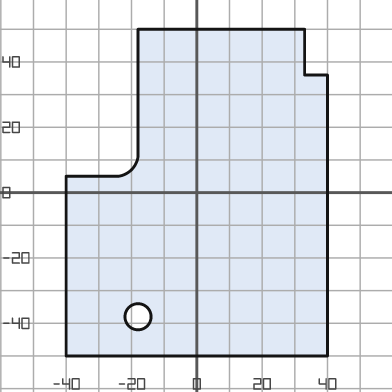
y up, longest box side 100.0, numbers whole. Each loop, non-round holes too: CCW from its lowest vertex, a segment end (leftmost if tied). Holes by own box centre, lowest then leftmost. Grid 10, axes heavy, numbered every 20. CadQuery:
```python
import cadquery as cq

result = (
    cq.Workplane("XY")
    .moveTo(-40.0, -50.0)
    .lineTo(40.0, -50.0)
    .lineTo(40.0, 36.0)
    .lineTo(33.0, 36.0)
    .lineTo(33.0, 50.0)
    .lineTo(-18.0, 50.0)
    .lineTo(-18.0, 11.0)
    .threePointArc((-20.0, 7.0), (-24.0, 5.0))
    .lineTo(-40.0, 5.0)
    .close()
    .moveTo(-18.0, -38.0)
    .circle(4.0)
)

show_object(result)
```